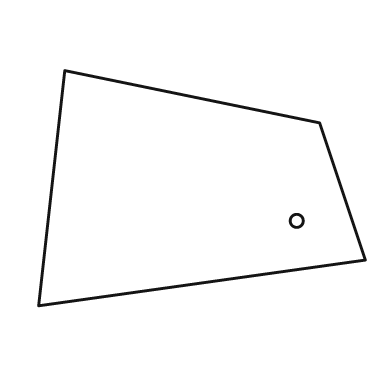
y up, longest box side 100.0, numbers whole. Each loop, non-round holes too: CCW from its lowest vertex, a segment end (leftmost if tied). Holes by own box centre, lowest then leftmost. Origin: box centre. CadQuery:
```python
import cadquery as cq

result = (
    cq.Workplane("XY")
    .moveTo(-50.0, -36.0)
    .lineTo(50.0, -22.0)
    .lineTo(36.0, 20.0)
    .lineTo(-42.0, 36.0)
    .close()
    .moveTo(29.0, -10.0)
    .circle(2.0)
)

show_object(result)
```